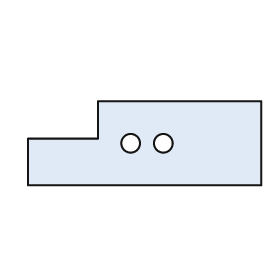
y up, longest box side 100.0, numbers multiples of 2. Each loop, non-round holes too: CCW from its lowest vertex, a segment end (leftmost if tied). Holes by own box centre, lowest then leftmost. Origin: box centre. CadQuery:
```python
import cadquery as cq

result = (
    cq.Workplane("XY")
    .moveTo(-50.0, -18.0)
    .lineTo(50.0, -18.0)
    .lineTo(50.0, 18.0)
    .lineTo(-20.0, 18.0)
    .lineTo(-20.0, 2.0)
    .lineTo(-50.0, 2.0)
    .close()
    .moveTo(-6.0, 0.0)
    .circle(4.0)
    .moveTo(8.0, 0.0)
    .circle(4.0)
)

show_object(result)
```